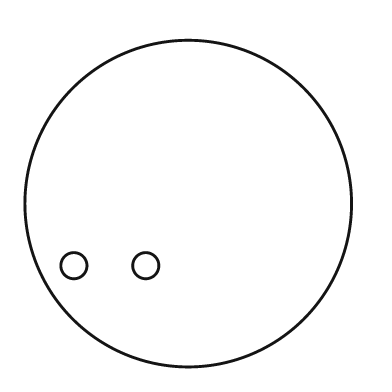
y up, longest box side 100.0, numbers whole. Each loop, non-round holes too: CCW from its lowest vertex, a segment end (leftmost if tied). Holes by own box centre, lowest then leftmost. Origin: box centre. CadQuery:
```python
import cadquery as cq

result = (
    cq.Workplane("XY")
    .moveTo(0.0, 0.0)
    .circle(50.0)
    .moveTo(-35.0, -19.0)
    .circle(4.0)
    .moveTo(-13.0, -19.0)
    .circle(4.0)
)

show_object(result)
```